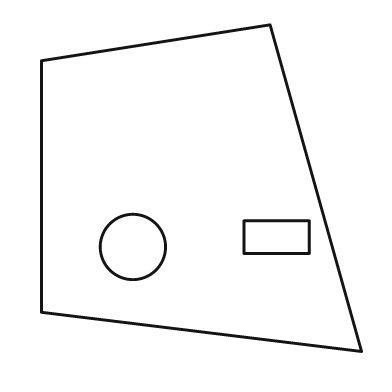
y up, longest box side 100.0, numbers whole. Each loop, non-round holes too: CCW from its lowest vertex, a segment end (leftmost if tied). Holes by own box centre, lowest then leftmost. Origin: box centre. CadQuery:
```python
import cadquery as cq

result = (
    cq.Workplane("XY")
    .moveTo(49.0, -50.0)
    .lineTo(21.0, 50.0)
    .lineTo(-49.0, 39.0)
    .lineTo(-49.0, -38.0)
    .close()
    .moveTo(-21.0, -18.0)
    .circle(10.0)
    .moveTo(13.0, -20.0)
    .lineTo(33.0, -20.0)
    .lineTo(33.0, -10.0)
    .lineTo(13.0, -10.0)
    .close()
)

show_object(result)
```